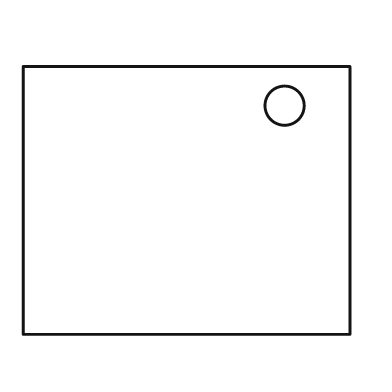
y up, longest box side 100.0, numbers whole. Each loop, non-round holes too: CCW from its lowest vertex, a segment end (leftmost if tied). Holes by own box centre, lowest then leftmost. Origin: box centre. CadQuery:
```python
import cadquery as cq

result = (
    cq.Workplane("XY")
    .moveTo(-50.0, -41.0)
    .lineTo(50.0, -41.0)
    .lineTo(50.0, 41.0)
    .lineTo(-50.0, 41.0)
    .close()
    .moveTo(30.0, 29.0)
    .circle(6.0)
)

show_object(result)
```